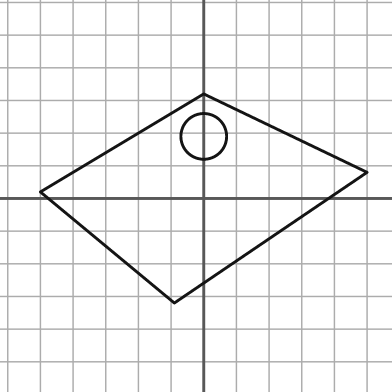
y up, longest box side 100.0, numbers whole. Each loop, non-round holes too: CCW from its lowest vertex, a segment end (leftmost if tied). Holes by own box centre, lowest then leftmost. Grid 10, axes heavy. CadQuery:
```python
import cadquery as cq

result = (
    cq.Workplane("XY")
    .moveTo(-9.0, -32.0)
    .lineTo(50.0, 8.0)
    .lineTo(0.0, 32.0)
    .lineTo(-50.0, 2.0)
    .close()
    .moveTo(0.0, 19.0)
    .circle(7.0)
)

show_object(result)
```